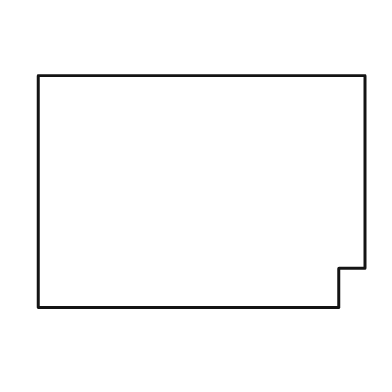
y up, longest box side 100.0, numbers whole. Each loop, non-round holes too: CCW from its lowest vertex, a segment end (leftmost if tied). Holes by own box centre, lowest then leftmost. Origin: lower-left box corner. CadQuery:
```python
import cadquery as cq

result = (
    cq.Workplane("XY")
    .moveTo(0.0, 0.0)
    .lineTo(92.0, 0.0)
    .lineTo(92.0, 12.0)
    .lineTo(100.0, 12.0)
    .lineTo(100.0, 71.0)
    .lineTo(0.0, 71.0)
    .close()
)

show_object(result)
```